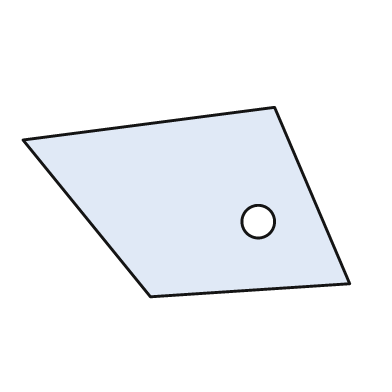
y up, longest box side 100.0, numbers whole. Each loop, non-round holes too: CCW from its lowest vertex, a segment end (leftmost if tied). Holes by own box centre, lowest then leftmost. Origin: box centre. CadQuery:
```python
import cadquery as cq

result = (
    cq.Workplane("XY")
    .moveTo(-11.0, -29.0)
    .lineTo(50.0, -25.0)
    .lineTo(27.0, 29.0)
    .lineTo(-50.0, 19.0)
    .close()
    .moveTo(22.0, -6.0)
    .circle(5.0)
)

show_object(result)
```